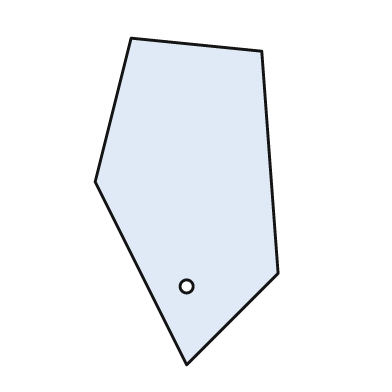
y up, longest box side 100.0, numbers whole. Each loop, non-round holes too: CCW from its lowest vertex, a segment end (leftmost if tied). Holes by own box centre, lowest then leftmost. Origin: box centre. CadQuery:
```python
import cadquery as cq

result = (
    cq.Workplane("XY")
    .moveTo(0.0, -50.0)
    .lineTo(28.0, -22.0)
    .lineTo(23.0, 46.0)
    .lineTo(-17.0, 50.0)
    .lineTo(-28.0, 6.0)
    .close()
    .moveTo(0.0, -26.0)
    .circle(2.0)
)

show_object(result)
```